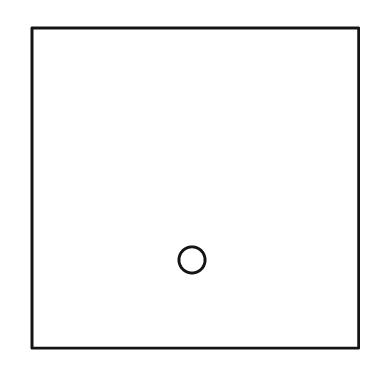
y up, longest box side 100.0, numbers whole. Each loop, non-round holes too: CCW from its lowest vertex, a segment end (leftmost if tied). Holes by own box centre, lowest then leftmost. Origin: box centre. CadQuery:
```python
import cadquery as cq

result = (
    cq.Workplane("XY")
    .moveTo(-50.0, -49.0)
    .lineTo(50.0, -49.0)
    .lineTo(50.0, 49.0)
    .lineTo(-50.0, 49.0)
    .close()
    .moveTo(-1.0, -22.0)
    .circle(4.0)
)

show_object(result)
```